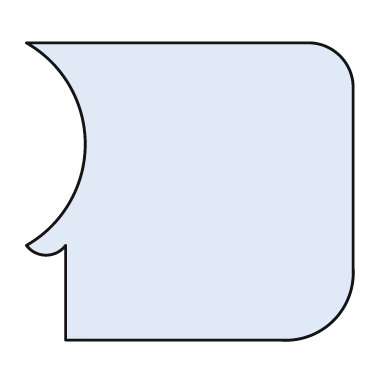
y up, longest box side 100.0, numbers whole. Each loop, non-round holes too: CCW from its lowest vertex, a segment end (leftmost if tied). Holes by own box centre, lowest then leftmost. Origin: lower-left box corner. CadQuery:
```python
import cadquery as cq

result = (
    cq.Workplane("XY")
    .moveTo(12.0, 0.0)
    .lineTo(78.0, 0.0)
    .threePointArc((94.0, 6.0), (100.0, 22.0))
    .lineTo(100.0, 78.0)
    .threePointArc((96.0, 87.0), (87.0, 91.0))
    .lineTo(0.0, 91.0)
    .threePointArc((18.0, 60.0), (0.0, 29.0))
    .threePointArc((6.0, 26.0), (12.0, 29.0))
    .close()
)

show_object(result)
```